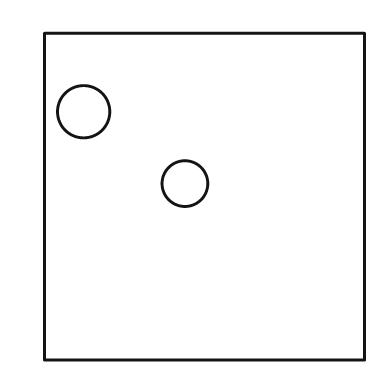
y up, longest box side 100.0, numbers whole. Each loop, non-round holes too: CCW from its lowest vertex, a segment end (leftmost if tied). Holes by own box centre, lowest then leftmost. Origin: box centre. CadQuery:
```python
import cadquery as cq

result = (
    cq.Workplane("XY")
    .moveTo(-49.0, -50.0)
    .lineTo(49.0, -50.0)
    .lineTo(49.0, 50.0)
    .lineTo(-49.0, 50.0)
    .close()
    .moveTo(-6.0, 4.0)
    .circle(7.0)
    .moveTo(-37.0, 26.0)
    .circle(8.0)
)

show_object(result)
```